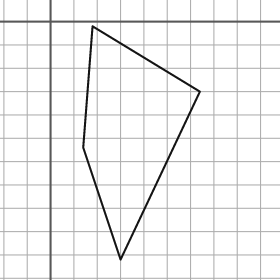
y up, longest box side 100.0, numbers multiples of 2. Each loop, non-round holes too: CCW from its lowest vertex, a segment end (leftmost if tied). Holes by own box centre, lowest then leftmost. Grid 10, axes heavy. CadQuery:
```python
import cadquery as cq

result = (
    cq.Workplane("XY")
    .moveTo(30.0, -102.0)
    .lineTo(64.0, -30.0)
    .lineTo(18.0, -2.0)
    .lineTo(14.0, -54.0)
    .close()
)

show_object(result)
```